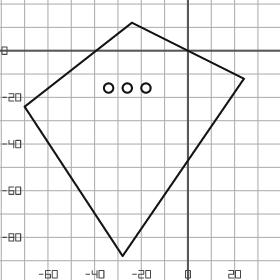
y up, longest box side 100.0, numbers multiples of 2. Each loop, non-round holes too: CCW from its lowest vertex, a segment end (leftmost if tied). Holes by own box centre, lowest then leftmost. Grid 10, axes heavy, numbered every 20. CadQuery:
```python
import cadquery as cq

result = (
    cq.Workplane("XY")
    .moveTo(-28.0, -88.0)
    .lineTo(24.0, -12.0)
    .lineTo(-24.0, 12.0)
    .lineTo(-70.0, -24.0)
    .close()
    .moveTo(-34.0, -16.0)
    .circle(2.0)
    .moveTo(-26.0, -16.0)
    .circle(2.0)
    .moveTo(-18.0, -16.0)
    .circle(2.0)
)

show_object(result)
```